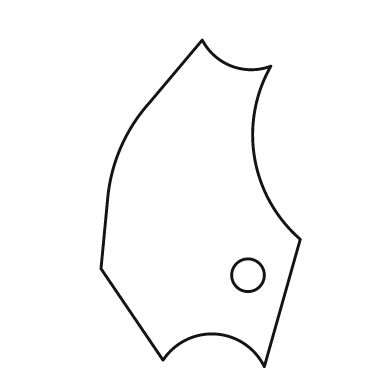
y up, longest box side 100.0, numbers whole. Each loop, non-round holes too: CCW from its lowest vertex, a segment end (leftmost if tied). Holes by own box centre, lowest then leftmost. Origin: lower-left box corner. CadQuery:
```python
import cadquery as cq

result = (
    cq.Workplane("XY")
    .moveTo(50.0, 0.0)
    .lineTo(61.0, 39.0)
    .threePointArc((47.0, 64.0), (52.0, 92.0))
    .threePointArc((40.0, 92.0), (31.0, 100.0))
    .lineTo(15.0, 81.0)
    .threePointArc((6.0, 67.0), (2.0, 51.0))
    .lineTo(0.0, 30.0)
    .lineTo(19.0, 2.0)
    .threePointArc((35.0, 10.0), (50.0, 0.0))
    .close()
    .moveTo(45.0, 28.0)
    .circle(5.0)
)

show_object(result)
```